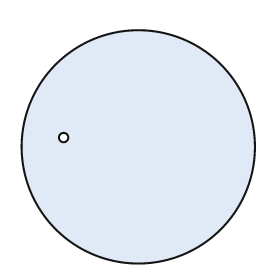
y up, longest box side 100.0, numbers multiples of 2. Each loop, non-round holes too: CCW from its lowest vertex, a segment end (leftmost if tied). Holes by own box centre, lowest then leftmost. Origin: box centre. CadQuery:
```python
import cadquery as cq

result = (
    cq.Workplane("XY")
    .moveTo(0.0, 0.0)
    .circle(50.0)
    .moveTo(-32.0, 4.0)
    .circle(2.0)
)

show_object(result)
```